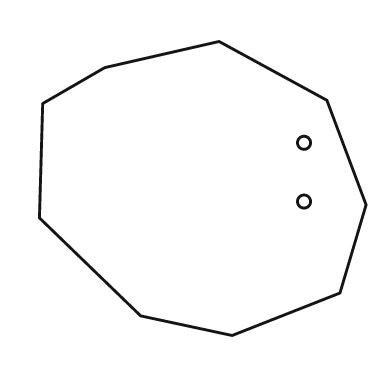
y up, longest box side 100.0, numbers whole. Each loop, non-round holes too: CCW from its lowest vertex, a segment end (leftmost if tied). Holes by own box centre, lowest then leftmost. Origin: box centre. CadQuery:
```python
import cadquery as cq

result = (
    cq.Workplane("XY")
    .moveTo(9.0, -45.0)
    .lineTo(42.0, -32.0)
    .lineTo(50.0, -5.0)
    .lineTo(38.0, 27.0)
    .lineTo(5.0, 45.0)
    .lineTo(-30.0, 37.0)
    .lineTo(-49.0, 26.0)
    .lineTo(-50.0, -9.0)
    .lineTo(-19.0, -39.0)
    .close()
    .moveTo(31.0, -4.0)
    .circle(2.0)
    .moveTo(31.0, 14.0)
    .circle(2.0)
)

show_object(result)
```